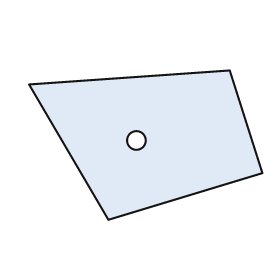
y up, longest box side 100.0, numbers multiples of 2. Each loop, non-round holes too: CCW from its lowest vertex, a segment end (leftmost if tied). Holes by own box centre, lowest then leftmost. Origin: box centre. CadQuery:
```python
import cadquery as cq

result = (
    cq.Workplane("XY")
    .moveTo(-16.0, -32.0)
    .lineTo(50.0, -12.0)
    .lineTo(36.0, 32.0)
    .lineTo(-50.0, 26.0)
    .close()
    .moveTo(-4.0, 2.0)
    .circle(4.0)
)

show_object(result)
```